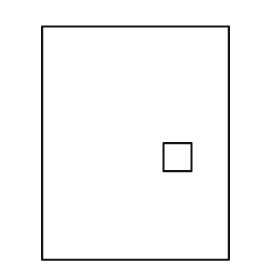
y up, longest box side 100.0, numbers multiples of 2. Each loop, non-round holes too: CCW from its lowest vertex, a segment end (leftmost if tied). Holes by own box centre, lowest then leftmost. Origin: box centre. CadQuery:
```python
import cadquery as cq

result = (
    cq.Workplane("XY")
    .moveTo(-40.0, -50.0)
    .lineTo(40.0, -50.0)
    .lineTo(40.0, 50.0)
    .lineTo(-40.0, 50.0)
    .close()
    .moveTo(12.0, -12.0)
    .lineTo(24.0, -12.0)
    .lineTo(24.0, 0.0)
    .lineTo(12.0, 0.0)
    .close()
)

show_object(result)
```